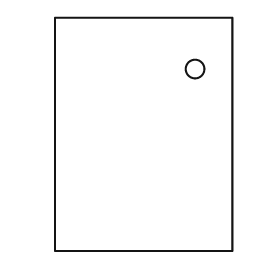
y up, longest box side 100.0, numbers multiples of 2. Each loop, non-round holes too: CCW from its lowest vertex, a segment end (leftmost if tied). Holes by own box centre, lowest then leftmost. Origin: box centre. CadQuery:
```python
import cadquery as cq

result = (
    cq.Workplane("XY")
    .moveTo(-38.0, -50.0)
    .lineTo(38.0, -50.0)
    .lineTo(38.0, 50.0)
    .lineTo(-38.0, 50.0)
    .close()
    .moveTo(22.0, 28.0)
    .circle(4.0)
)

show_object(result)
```